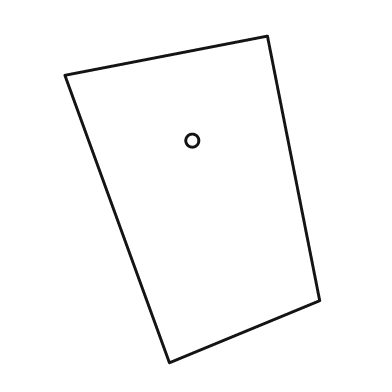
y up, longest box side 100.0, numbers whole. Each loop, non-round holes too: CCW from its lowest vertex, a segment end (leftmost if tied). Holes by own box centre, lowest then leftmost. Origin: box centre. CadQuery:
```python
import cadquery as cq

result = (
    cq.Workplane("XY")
    .moveTo(-7.0, -50.0)
    .lineTo(39.0, -31.0)
    .lineTo(23.0, 50.0)
    .lineTo(-39.0, 38.0)
    .close()
    .moveTo(0.0, 18.0)
    .circle(2.0)
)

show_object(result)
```